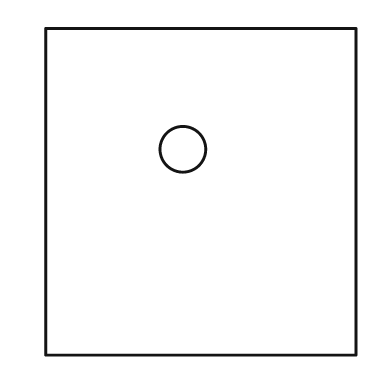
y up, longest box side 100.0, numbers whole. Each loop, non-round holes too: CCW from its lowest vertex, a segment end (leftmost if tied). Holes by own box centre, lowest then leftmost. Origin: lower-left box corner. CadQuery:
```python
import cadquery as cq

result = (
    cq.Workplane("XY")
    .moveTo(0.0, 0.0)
    .lineTo(95.0, 0.0)
    .lineTo(95.0, 100.0)
    .lineTo(0.0, 100.0)
    .close()
    .moveTo(42.0, 63.0)
    .circle(7.0)
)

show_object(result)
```